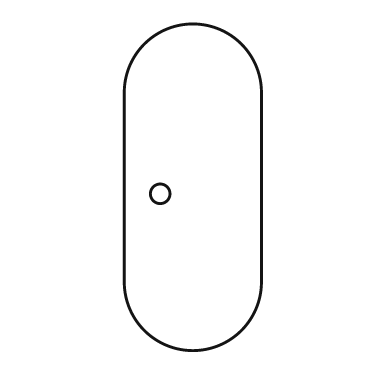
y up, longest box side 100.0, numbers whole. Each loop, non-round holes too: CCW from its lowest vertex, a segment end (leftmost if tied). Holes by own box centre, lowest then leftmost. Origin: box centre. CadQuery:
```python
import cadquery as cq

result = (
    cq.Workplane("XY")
    .moveTo(-21.0, -29.0)
    .threePointArc((0.0, -50.0), (21.0, -29.0))
    .lineTo(21.0, 29.0)
    .threePointArc((0.0, 50.0), (-21.0, 29.0))
    .close()
    .moveTo(-10.0, -2.0)
    .circle(3.0)
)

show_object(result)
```